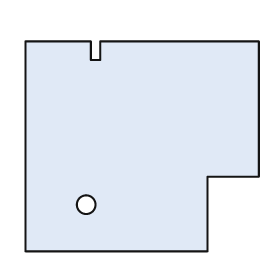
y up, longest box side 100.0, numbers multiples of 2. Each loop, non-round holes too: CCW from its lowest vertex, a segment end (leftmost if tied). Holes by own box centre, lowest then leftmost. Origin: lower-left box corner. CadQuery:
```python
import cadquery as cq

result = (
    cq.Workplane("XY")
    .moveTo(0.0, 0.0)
    .lineTo(78.0, 0.0)
    .lineTo(78.0, 32.0)
    .lineTo(100.0, 32.0)
    .lineTo(100.0, 90.0)
    .lineTo(32.0, 90.0)
    .lineTo(32.0, 82.0)
    .lineTo(28.0, 82.0)
    .lineTo(28.0, 90.0)
    .lineTo(0.0, 90.0)
    .close()
    .moveTo(26.0, 20.0)
    .circle(4.0)
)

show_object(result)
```